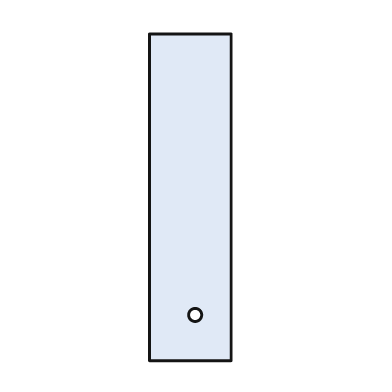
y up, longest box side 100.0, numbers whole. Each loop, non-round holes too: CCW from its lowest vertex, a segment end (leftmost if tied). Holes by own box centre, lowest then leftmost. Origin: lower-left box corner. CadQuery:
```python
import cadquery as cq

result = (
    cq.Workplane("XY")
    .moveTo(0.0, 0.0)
    .lineTo(25.0, 0.0)
    .lineTo(25.0, 100.0)
    .lineTo(0.0, 100.0)
    .close()
    .moveTo(14.0, 14.0)
    .circle(2.0)
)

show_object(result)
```